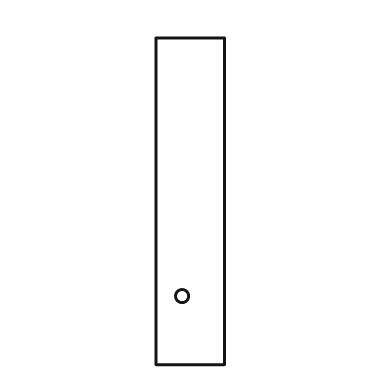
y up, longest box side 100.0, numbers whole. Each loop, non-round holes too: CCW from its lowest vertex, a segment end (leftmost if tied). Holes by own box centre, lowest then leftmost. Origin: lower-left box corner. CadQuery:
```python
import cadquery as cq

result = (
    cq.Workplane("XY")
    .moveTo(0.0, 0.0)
    .lineTo(21.0, 0.0)
    .lineTo(21.0, 100.0)
    .lineTo(0.0, 100.0)
    .close()
    .moveTo(8.0, 21.0)
    .circle(2.0)
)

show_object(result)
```